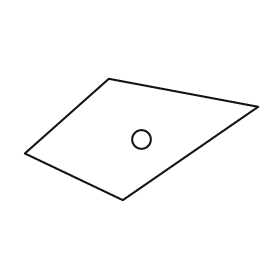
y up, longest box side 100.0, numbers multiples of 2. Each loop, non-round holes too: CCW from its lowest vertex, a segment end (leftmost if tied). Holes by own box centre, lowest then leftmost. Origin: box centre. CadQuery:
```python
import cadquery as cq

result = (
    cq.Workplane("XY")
    .moveTo(-8.0, -26.0)
    .lineTo(50.0, 14.0)
    .lineTo(-14.0, 26.0)
    .lineTo(-50.0, -6.0)
    .close()
    .moveTo(0.0, 0.0)
    .circle(4.0)
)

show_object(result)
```